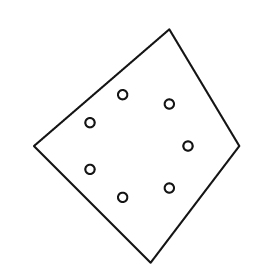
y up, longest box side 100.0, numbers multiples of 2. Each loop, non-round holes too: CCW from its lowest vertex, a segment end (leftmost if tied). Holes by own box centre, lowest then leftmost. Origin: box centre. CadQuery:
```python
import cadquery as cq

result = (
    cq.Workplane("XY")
    .moveTo(6.0, -50.0)
    .lineTo(44.0, 0.0)
    .lineTo(14.0, 50.0)
    .lineTo(-44.0, 0.0)
    .close()
    .moveTo(-6.0, -22.0)
    .circle(2.0)
    .moveTo(14.0, -18.0)
    .circle(2.0)
    .moveTo(-20.0, -10.0)
    .circle(2.0)
    .moveTo(22.0, 0.0)
    .circle(2.0)
    .moveTo(-20.0, 10.0)
    .circle(2.0)
    .moveTo(14.0, 18.0)
    .circle(2.0)
    .moveTo(-6.0, 22.0)
    .circle(2.0)
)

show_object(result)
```